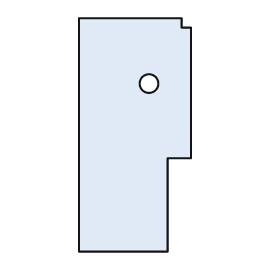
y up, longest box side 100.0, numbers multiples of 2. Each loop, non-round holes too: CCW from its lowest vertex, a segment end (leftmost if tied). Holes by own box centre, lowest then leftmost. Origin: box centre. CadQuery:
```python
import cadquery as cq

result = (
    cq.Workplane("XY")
    .moveTo(-24.0, -50.0)
    .lineTo(14.0, -50.0)
    .lineTo(14.0, -10.0)
    .lineTo(24.0, -10.0)
    .lineTo(24.0, 46.0)
    .lineTo(20.0, 46.0)
    .lineTo(20.0, 50.0)
    .lineTo(-24.0, 50.0)
    .close()
    .moveTo(6.0, 22.0)
    .circle(4.0)
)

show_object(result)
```